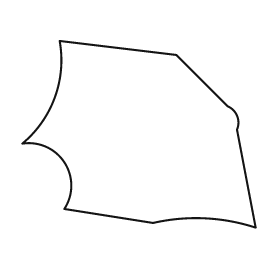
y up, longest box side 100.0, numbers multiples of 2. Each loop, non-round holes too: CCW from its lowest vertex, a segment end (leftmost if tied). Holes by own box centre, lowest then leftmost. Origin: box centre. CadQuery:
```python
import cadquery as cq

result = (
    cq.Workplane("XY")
    .moveTo(50.0, -40.0)
    .lineTo(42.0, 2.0)
    .threePointArc((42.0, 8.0), (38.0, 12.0))
    .lineTo(16.0, 34.0)
    .lineTo(-34.0, 40.0)
    .threePointArc((-36.0, 16.0), (-50.0, -4.0))
    .threePointArc((-32.0, -12.0), (-32.0, -32.0))
    .lineTo(6.0, -38.0)
    .threePointArc((28.0, -36.0), (50.0, -40.0))
    .close()
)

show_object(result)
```